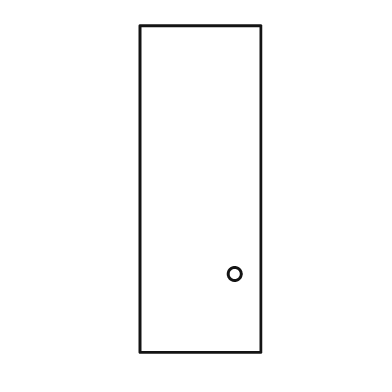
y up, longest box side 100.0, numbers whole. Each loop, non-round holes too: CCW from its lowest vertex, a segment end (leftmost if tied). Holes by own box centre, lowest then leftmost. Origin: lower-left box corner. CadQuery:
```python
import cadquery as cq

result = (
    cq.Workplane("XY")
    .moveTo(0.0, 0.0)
    .lineTo(37.0, 0.0)
    .lineTo(37.0, 100.0)
    .lineTo(0.0, 100.0)
    .close()
    .moveTo(29.0, 24.0)
    .circle(2.0)
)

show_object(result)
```